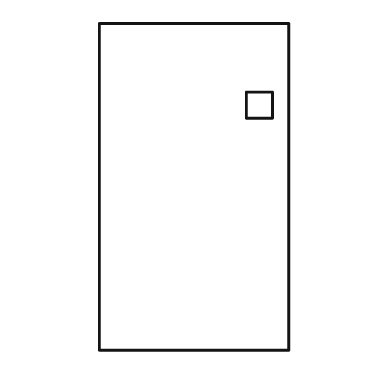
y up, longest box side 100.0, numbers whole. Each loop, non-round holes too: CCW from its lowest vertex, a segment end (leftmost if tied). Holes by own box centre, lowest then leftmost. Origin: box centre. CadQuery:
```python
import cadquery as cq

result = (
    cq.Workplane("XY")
    .moveTo(-29.0, -50.0)
    .lineTo(29.0, -50.0)
    .lineTo(29.0, 50.0)
    .lineTo(-29.0, 50.0)
    .close()
    .moveTo(16.0, 21.0)
    .lineTo(24.0, 21.0)
    .lineTo(24.0, 29.0)
    .lineTo(16.0, 29.0)
    .close()
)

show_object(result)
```